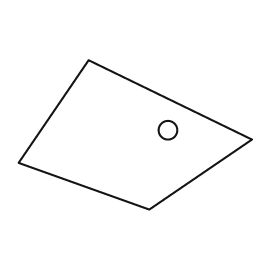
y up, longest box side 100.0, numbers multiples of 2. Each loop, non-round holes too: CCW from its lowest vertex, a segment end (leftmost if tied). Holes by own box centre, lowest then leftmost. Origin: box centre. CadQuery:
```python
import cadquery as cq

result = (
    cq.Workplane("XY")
    .moveTo(6.0, -32.0)
    .lineTo(50.0, -2.0)
    .lineTo(-20.0, 32.0)
    .lineTo(-50.0, -12.0)
    .close()
    .moveTo(14.0, 2.0)
    .circle(4.0)
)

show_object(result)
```